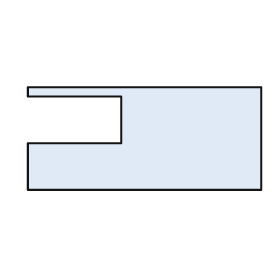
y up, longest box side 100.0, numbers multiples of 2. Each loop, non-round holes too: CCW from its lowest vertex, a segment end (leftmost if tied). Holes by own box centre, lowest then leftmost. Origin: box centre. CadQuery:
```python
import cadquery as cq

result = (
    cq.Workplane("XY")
    .moveTo(-50.0, -22.0)
    .lineTo(50.0, -22.0)
    .lineTo(50.0, 22.0)
    .lineTo(-50.0, 22.0)
    .lineTo(-50.0, 18.0)
    .lineTo(-10.0, 18.0)
    .lineTo(-10.0, -2.0)
    .lineTo(-50.0, -2.0)
    .close()
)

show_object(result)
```